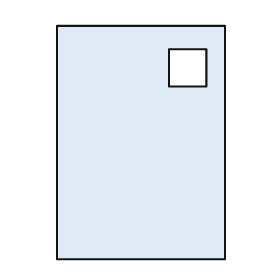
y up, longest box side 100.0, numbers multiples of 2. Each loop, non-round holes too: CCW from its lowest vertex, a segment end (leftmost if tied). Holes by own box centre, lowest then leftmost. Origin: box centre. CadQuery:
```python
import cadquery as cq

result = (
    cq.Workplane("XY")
    .moveTo(-36.0, -50.0)
    .lineTo(36.0, -50.0)
    .lineTo(36.0, 50.0)
    .lineTo(-36.0, 50.0)
    .close()
    .moveTo(12.0, 24.0)
    .lineTo(28.0, 24.0)
    .lineTo(28.0, 40.0)
    .lineTo(12.0, 40.0)
    .close()
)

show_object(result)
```